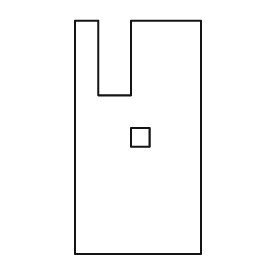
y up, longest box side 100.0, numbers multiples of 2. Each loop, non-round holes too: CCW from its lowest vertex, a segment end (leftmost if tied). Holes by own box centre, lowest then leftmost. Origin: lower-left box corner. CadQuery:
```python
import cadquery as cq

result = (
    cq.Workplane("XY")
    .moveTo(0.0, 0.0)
    .lineTo(54.0, 0.0)
    .lineTo(54.0, 100.0)
    .lineTo(24.0, 100.0)
    .lineTo(24.0, 68.0)
    .lineTo(10.0, 68.0)
    .lineTo(10.0, 100.0)
    .lineTo(0.0, 100.0)
    .close()
    .moveTo(24.0, 46.0)
    .lineTo(32.0, 46.0)
    .lineTo(32.0, 54.0)
    .lineTo(24.0, 54.0)
    .close()
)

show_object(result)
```